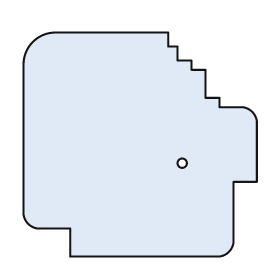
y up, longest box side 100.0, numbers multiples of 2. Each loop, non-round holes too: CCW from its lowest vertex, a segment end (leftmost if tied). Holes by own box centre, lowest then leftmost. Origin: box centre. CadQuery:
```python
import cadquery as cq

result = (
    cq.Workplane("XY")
    .moveTo(-30.0, -48.0)
    .lineTo(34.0, -48.0)
    .threePointArc((38.0, -46.0), (40.0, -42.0))
    .lineTo(40.0, -16.0)
    .lineTo(50.0, -16.0)
    .lineTo(50.0, 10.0)
    .threePointArc((48.0, 14.0), (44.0, 16.0))
    .lineTo(34.0, 16.0)
    .lineTo(34.0, 20.0)
    .lineTo(28.0, 20.0)
    .lineTo(28.0, 32.0)
    .lineTo(22.0, 32.0)
    .lineTo(22.0, 36.0)
    .lineTo(16.0, 36.0)
    .lineTo(16.0, 42.0)
    .lineTo(12.0, 42.0)
    .lineTo(12.0, 48.0)
    .lineTo(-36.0, 48.0)
    .threePointArc((-46.0, 44.0), (-50.0, 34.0))
    .lineTo(-50.0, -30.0)
    .threePointArc((-48.0, -34.0), (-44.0, -36.0))
    .lineTo(-30.0, -36.0)
    .close()
    .moveTo(18.0, -8.0)
    .circle(2.0)
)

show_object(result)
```